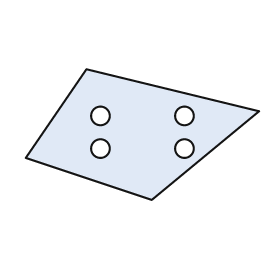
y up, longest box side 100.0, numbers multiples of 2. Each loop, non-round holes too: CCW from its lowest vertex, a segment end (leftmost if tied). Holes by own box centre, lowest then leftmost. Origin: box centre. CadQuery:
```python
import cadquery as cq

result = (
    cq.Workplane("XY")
    .moveTo(4.0, -28.0)
    .lineTo(50.0, 10.0)
    .lineTo(-24.0, 28.0)
    .lineTo(-50.0, -10.0)
    .close()
    .moveTo(-18.0, -6.0)
    .circle(4.0)
    .moveTo(18.0, -6.0)
    .circle(4.0)
    .moveTo(-18.0, 8.0)
    .circle(4.0)
    .moveTo(18.0, 8.0)
    .circle(4.0)
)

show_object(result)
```